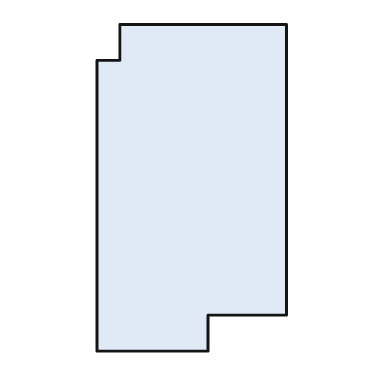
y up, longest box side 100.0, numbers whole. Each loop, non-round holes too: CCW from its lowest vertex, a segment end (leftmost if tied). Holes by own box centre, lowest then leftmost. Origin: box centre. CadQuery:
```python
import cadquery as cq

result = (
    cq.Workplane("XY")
    .moveTo(-29.0, -50.0)
    .lineTo(5.0, -50.0)
    .lineTo(5.0, -39.0)
    .lineTo(29.0, -39.0)
    .lineTo(29.0, 50.0)
    .lineTo(-22.0, 50.0)
    .lineTo(-22.0, 39.0)
    .lineTo(-29.0, 39.0)
    .close()
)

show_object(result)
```